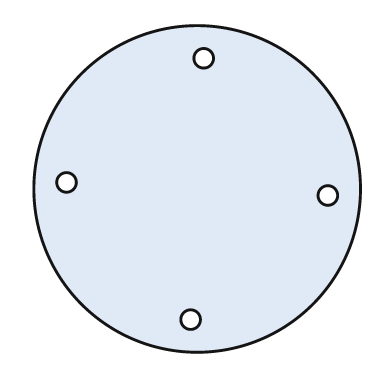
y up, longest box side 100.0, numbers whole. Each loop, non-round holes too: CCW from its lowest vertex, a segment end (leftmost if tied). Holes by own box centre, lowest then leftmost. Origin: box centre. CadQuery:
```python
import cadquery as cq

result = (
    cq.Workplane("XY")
    .moveTo(0.0, 0.0)
    .circle(50.0)
    .moveTo(-2.0, -40.0)
    .circle(3.0)
    .moveTo(40.0, -2.0)
    .circle(3.0)
    .moveTo(-40.0, 2.0)
    .circle(3.0)
    .moveTo(2.0, 40.0)
    .circle(3.0)
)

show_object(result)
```